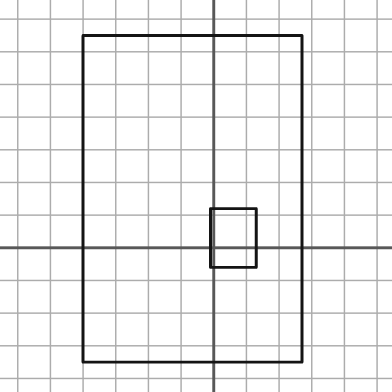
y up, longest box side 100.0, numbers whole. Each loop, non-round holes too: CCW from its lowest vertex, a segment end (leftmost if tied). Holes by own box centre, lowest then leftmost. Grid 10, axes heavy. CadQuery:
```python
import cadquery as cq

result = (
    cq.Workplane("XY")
    .moveTo(-40.0, -35.0)
    .lineTo(27.0, -35.0)
    .lineTo(27.0, 65.0)
    .lineTo(-40.0, 65.0)
    .close()
    .moveTo(-1.0, -6.0)
    .lineTo(13.0, -6.0)
    .lineTo(13.0, 12.0)
    .lineTo(-1.0, 12.0)
    .close()
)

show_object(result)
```